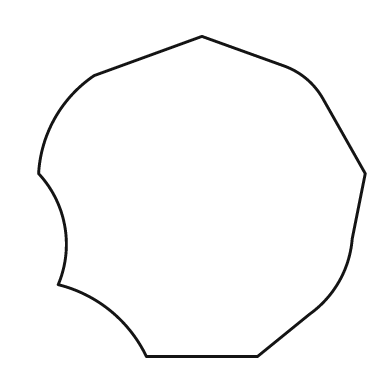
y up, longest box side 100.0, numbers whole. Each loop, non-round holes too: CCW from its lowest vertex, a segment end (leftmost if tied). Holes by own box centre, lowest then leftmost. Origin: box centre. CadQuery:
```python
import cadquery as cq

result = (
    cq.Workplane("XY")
    .moveTo(-17.0, -49.0)
    .lineTo(17.0, -49.0)
    .lineTo(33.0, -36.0)
    .threePointArc((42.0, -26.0), (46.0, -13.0))
    .lineTo(50.0, 7.0)
    .lineTo(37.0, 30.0)
    .threePointArc((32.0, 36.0), (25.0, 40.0))
    .lineTo(0.0, 49.0)
    .lineTo(-33.0, 37.0)
    .threePointArc((-45.0, 24.0), (-50.0, 7.0))
    .threePointArc((-42.0, -9.0), (-44.0, -27.0))
    .threePointArc((-28.0, -35.0), (-17.0, -49.0))
    .close()
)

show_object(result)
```